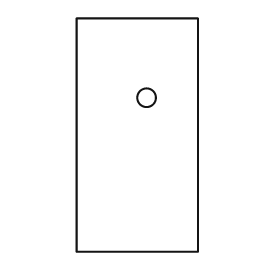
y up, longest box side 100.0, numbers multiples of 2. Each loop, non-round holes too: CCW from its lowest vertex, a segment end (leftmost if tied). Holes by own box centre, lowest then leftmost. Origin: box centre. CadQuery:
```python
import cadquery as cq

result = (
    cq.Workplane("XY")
    .moveTo(-26.0, -50.0)
    .lineTo(26.0, -50.0)
    .lineTo(26.0, 50.0)
    .lineTo(-26.0, 50.0)
    .close()
    .moveTo(4.0, 16.0)
    .circle(4.0)
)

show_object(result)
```